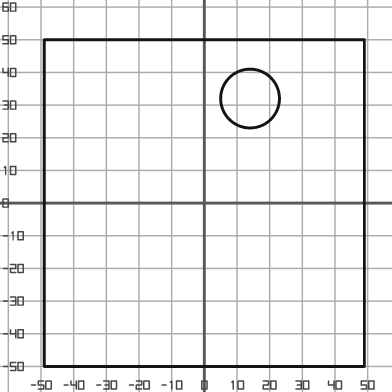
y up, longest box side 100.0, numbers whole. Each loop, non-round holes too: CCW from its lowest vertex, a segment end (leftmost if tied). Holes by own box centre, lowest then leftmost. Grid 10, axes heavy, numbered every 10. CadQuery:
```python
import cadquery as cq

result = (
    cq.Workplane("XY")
    .moveTo(-49.0, -50.0)
    .lineTo(49.0, -50.0)
    .lineTo(49.0, 50.0)
    .lineTo(-49.0, 50.0)
    .close()
    .moveTo(14.0, 32.0)
    .circle(9.0)
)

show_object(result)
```